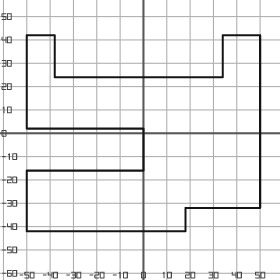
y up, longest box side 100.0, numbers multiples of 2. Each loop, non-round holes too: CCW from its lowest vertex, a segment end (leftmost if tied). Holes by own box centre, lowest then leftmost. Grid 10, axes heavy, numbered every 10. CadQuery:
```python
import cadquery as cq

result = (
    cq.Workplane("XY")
    .moveTo(-50.0, -42.0)
    .lineTo(18.0, -42.0)
    .lineTo(18.0, -32.0)
    .lineTo(50.0, -32.0)
    .lineTo(50.0, 42.0)
    .lineTo(34.0, 42.0)
    .lineTo(34.0, 24.0)
    .lineTo(-38.0, 24.0)
    .lineTo(-38.0, 42.0)
    .lineTo(-50.0, 42.0)
    .lineTo(-50.0, 2.0)
    .lineTo(0.0, 2.0)
    .lineTo(0.0, -16.0)
    .lineTo(-50.0, -16.0)
    .close()
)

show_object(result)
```